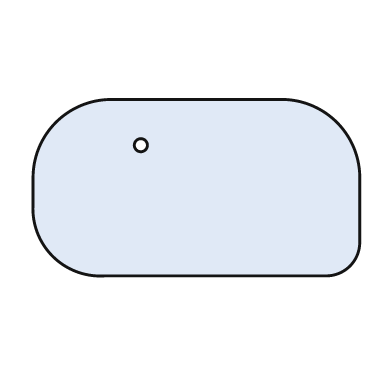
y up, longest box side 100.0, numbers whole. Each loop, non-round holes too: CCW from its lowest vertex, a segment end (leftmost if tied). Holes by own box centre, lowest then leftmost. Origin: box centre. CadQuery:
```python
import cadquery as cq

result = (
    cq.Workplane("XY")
    .moveTo(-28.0, -27.0)
    .lineTo(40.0, -27.0)
    .threePointArc((47.0, -24.0), (50.0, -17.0))
    .lineTo(50.0, 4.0)
    .threePointArc((43.0, 20.0), (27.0, 27.0))
    .lineTo(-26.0, 27.0)
    .threePointArc((-43.0, 20.0), (-50.0, 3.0))
    .lineTo(-50.0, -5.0)
    .threePointArc((-44.0, -21.0), (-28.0, -27.0))
    .close()
    .moveTo(-17.0, 13.0)
    .circle(2.0)
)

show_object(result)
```